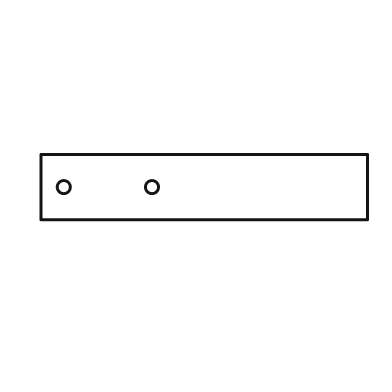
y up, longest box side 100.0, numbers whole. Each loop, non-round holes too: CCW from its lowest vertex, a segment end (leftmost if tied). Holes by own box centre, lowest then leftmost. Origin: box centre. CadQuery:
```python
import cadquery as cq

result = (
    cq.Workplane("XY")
    .moveTo(-50.0, -10.0)
    .lineTo(50.0, -10.0)
    .lineTo(50.0, 10.0)
    .lineTo(-50.0, 10.0)
    .close()
    .moveTo(-43.0, 0.0)
    .circle(2.0)
    .moveTo(-16.0, 0.0)
    .circle(2.0)
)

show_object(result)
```